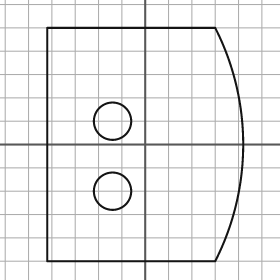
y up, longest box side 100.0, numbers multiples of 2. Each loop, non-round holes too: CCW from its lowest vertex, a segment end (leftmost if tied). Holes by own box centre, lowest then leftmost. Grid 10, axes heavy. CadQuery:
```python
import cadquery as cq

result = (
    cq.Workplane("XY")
    .moveTo(-42.0, -50.0)
    .lineTo(30.0, -50.0)
    .threePointArc((42.0, 0.0), (30.0, 50.0))
    .lineTo(-42.0, 50.0)
    .close()
    .moveTo(-14.0, -20.0)
    .circle(8.0)
    .moveTo(-14.0, 10.0)
    .circle(8.0)
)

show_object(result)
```